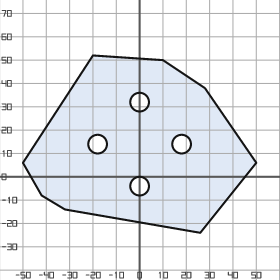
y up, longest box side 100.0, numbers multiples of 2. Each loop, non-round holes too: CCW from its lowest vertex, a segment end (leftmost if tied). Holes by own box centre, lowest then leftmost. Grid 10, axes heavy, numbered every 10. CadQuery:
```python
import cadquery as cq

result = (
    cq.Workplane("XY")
    .moveTo(26.0, -24.0)
    .lineTo(50.0, 6.0)
    .lineTo(28.0, 38.0)
    .lineTo(10.0, 50.0)
    .lineTo(-20.0, 52.0)
    .lineTo(-50.0, 6.0)
    .lineTo(-42.0, -8.0)
    .lineTo(-32.0, -14.0)
    .close()
    .moveTo(0.0, -4.0)
    .circle(4.0)
    .moveTo(-18.0, 14.0)
    .circle(4.0)
    .moveTo(18.0, 14.0)
    .circle(4.0)
    .moveTo(0.0, 32.0)
    .circle(4.0)
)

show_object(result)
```